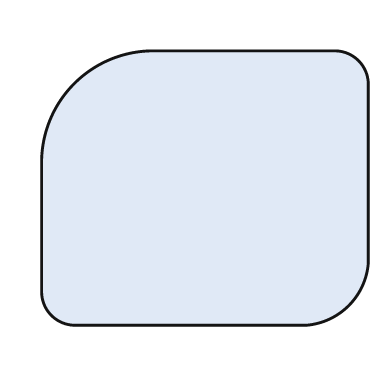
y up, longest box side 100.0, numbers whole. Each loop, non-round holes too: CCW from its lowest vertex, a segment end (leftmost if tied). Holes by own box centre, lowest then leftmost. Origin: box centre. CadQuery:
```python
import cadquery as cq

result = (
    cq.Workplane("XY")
    .moveTo(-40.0, -42.0)
    .lineTo(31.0, -42.0)
    .threePointArc((44.0, -36.0), (50.0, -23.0))
    .lineTo(50.0, 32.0)
    .threePointArc((47.0, 39.0), (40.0, 42.0))
    .lineTo(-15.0, 42.0)
    .threePointArc((-40.0, 32.0), (-50.0, 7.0))
    .lineTo(-50.0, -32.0)
    .threePointArc((-47.0, -39.0), (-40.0, -42.0))
    .close()
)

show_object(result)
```